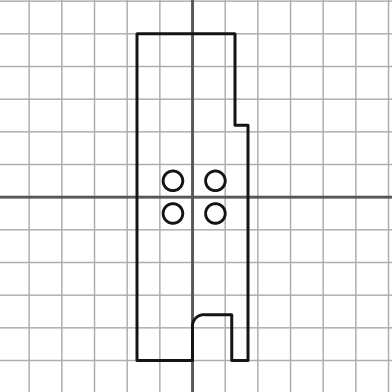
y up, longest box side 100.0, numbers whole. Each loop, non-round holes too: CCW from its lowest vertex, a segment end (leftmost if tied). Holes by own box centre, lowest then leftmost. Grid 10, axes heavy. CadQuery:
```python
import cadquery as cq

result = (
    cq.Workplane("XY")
    .moveTo(-17.0, -50.0)
    .lineTo(0.0, -50.0)
    .lineTo(0.0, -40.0)
    .threePointArc((1.0, -37.0), (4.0, -36.0))
    .lineTo(12.0, -36.0)
    .lineTo(12.0, -50.0)
    .lineTo(17.0, -50.0)
    .lineTo(17.0, 22.0)
    .lineTo(13.0, 22.0)
    .lineTo(13.0, 50.0)
    .lineTo(-17.0, 50.0)
    .close()
    .moveTo(-6.0, -5.0)
    .circle(3.0)
    .moveTo(7.0, -5.0)
    .circle(3.0)
    .moveTo(-6.0, 5.0)
    .circle(3.0)
    .moveTo(7.0, 5.0)
    .circle(3.0)
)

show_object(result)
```